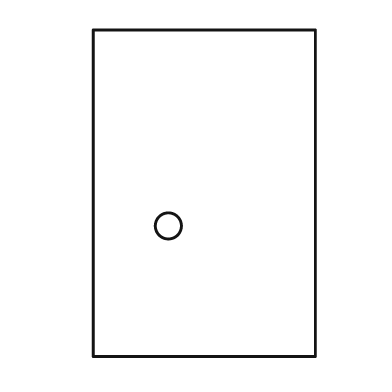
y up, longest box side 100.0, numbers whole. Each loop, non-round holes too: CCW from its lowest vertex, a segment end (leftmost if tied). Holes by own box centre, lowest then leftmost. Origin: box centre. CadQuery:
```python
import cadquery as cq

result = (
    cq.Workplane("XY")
    .moveTo(-34.0, -50.0)
    .lineTo(34.0, -50.0)
    .lineTo(34.0, 50.0)
    .lineTo(-34.0, 50.0)
    .close()
    .moveTo(-11.0, -10.0)
    .circle(4.0)
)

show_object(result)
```